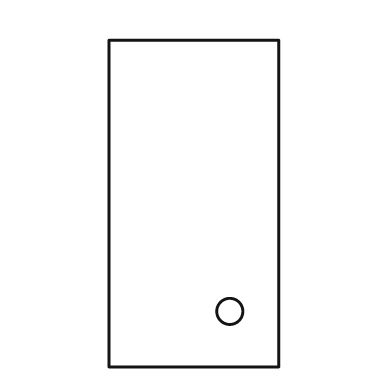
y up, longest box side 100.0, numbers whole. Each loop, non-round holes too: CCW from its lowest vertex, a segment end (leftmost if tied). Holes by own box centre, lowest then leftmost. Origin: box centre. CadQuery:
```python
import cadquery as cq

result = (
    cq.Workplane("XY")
    .moveTo(-26.0, -50.0)
    .lineTo(26.0, -50.0)
    .lineTo(26.0, 50.0)
    .lineTo(-26.0, 50.0)
    .close()
    .moveTo(11.0, -33.0)
    .circle(4.0)
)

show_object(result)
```